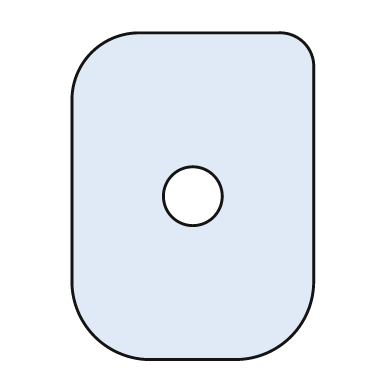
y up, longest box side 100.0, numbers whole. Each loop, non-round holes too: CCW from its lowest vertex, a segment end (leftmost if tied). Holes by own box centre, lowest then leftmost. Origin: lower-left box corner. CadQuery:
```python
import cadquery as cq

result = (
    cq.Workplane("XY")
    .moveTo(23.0, 0.0)
    .lineTo(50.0, 0.0)
    .threePointArc((67.0, 7.0), (74.0, 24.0))
    .lineTo(74.0, 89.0)
    .threePointArc((71.0, 97.0), (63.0, 100.0))
    .lineTo(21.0, 100.0)
    .threePointArc((6.0, 94.0), (0.0, 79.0))
    .lineTo(0.0, 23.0)
    .threePointArc((7.0, 7.0), (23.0, 0.0))
    .close()
    .moveTo(37.0, 50.0)
    .circle(9.0)
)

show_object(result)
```